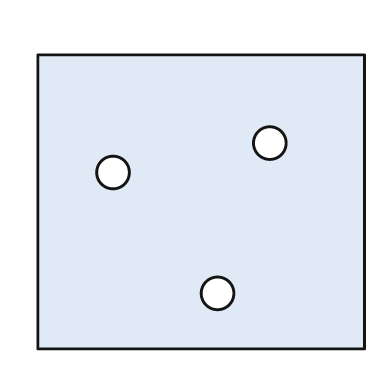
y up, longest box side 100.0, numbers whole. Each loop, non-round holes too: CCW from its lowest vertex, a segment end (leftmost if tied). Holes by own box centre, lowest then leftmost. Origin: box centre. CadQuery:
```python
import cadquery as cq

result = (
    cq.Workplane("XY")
    .moveTo(-50.0, -45.0)
    .lineTo(50.0, -45.0)
    .lineTo(50.0, 45.0)
    .lineTo(-50.0, 45.0)
    .close()
    .moveTo(5.0, -28.0)
    .circle(5.0)
    .moveTo(-27.0, 9.0)
    .circle(5.0)
    .moveTo(21.0, 18.0)
    .circle(5.0)
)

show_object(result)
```